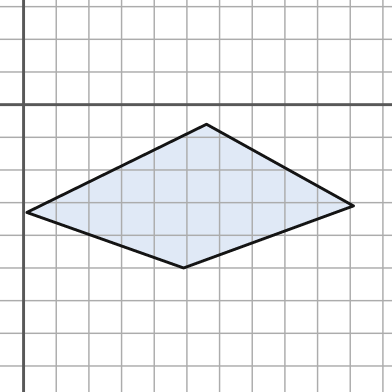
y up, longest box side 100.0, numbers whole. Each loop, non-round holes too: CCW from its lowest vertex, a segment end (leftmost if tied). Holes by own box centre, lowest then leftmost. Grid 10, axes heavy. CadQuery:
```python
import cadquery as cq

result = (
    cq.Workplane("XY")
    .moveTo(49.0, -50.0)
    .lineTo(101.0, -31.0)
    .lineTo(56.0, -6.0)
    .lineTo(1.0, -33.0)
    .close()
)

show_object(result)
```